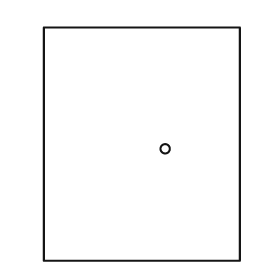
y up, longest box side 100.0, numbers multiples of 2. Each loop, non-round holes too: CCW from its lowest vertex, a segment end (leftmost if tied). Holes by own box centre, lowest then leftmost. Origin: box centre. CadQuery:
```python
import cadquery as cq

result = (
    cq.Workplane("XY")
    .moveTo(-42.0, -50.0)
    .lineTo(42.0, -50.0)
    .lineTo(42.0, 50.0)
    .lineTo(-42.0, 50.0)
    .close()
    .moveTo(10.0, -2.0)
    .circle(2.0)
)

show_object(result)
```